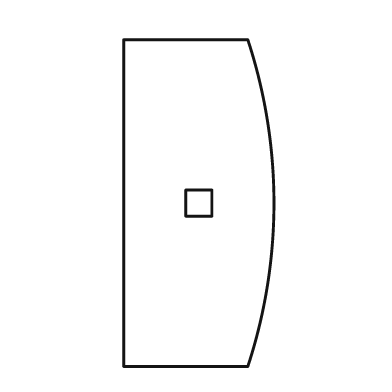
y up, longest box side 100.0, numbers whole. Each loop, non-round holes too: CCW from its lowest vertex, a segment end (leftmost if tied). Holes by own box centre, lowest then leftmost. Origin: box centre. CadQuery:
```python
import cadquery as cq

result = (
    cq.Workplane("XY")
    .moveTo(-23.0, -50.0)
    .lineTo(15.0, -50.0)
    .threePointArc((23.0, 0.0), (15.0, 50.0))
    .lineTo(-23.0, 50.0)
    .close()
    .moveTo(-4.0, -4.0)
    .lineTo(4.0, -4.0)
    .lineTo(4.0, 4.0)
    .lineTo(-4.0, 4.0)
    .close()
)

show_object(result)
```